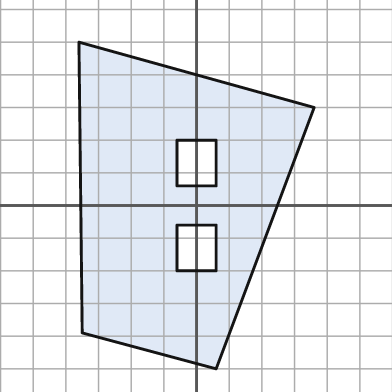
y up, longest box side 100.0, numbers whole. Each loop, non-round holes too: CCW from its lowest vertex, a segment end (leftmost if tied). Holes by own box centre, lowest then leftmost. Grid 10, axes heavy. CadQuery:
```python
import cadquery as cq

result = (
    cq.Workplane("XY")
    .moveTo(6.0, -50.0)
    .lineTo(36.0, 30.0)
    .lineTo(-36.0, 50.0)
    .lineTo(-35.0, -39.0)
    .close()
    .moveTo(-6.0, -20.0)
    .lineTo(6.0, -20.0)
    .lineTo(6.0, -6.0)
    .lineTo(-6.0, -6.0)
    .close()
    .moveTo(-6.0, 6.0)
    .lineTo(6.0, 6.0)
    .lineTo(6.0, 20.0)
    .lineTo(-6.0, 20.0)
    .close()
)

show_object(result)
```